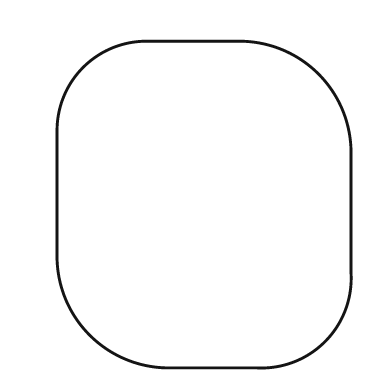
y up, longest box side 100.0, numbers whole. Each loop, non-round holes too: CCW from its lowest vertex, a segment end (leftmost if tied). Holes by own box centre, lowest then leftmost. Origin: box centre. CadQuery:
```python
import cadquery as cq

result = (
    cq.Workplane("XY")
    .moveTo(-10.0, -50.0)
    .lineTo(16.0, -50.0)
    .threePointArc((37.0, -42.0), (45.0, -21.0))
    .lineTo(45.0, 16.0)
    .threePointArc((35.0, 40.0), (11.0, 50.0))
    .lineTo(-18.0, 50.0)
    .threePointArc((-37.0, 42.0), (-45.0, 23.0))
    .lineTo(-45.0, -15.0)
    .threePointArc((-35.0, -40.0), (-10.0, -50.0))
    .close()
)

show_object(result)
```